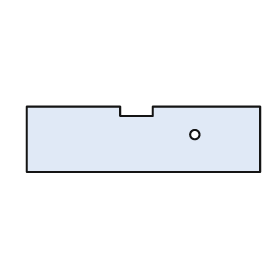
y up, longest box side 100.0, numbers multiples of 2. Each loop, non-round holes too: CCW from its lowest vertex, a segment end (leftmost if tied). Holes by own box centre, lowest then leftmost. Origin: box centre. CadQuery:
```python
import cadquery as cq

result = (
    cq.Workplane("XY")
    .moveTo(-50.0, -14.0)
    .lineTo(50.0, -14.0)
    .lineTo(50.0, 14.0)
    .lineTo(4.0, 14.0)
    .lineTo(4.0, 10.0)
    .lineTo(-10.0, 10.0)
    .lineTo(-10.0, 14.0)
    .lineTo(-50.0, 14.0)
    .close()
    .moveTo(22.0, 2.0)
    .circle(2.0)
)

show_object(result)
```